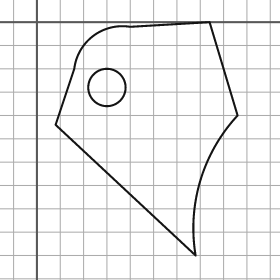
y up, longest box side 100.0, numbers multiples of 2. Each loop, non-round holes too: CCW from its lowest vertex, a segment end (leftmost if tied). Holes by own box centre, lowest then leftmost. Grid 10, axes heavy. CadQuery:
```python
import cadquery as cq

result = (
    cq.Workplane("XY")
    .moveTo(68.0, -100.0)
    .threePointArc((70.0, -68.0), (86.0, -40.0))
    .lineTo(74.0, 0.0)
    .lineTo(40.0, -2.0)
    .threePointArc((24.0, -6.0), (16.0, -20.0))
    .lineTo(8.0, -44.0)
    .close()
    .moveTo(30.0, -28.0)
    .circle(8.0)
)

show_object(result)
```